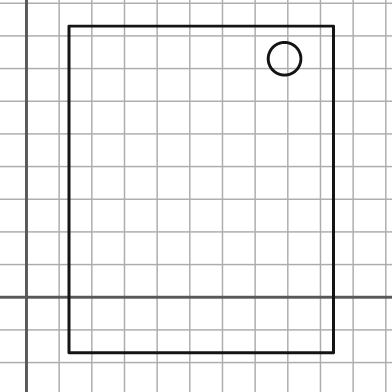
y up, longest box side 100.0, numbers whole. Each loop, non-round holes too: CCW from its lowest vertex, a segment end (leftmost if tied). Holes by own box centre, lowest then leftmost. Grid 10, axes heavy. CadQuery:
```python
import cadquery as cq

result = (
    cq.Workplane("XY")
    .moveTo(13.0, -17.0)
    .lineTo(94.0, -17.0)
    .lineTo(94.0, 83.0)
    .lineTo(13.0, 83.0)
    .close()
    .moveTo(79.0, 73.0)
    .circle(5.0)
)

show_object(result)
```